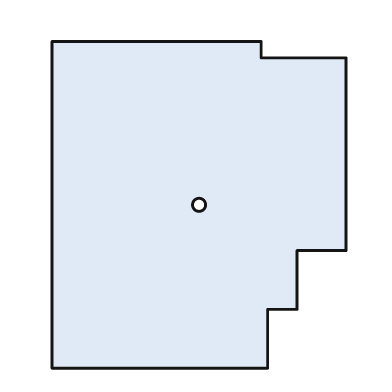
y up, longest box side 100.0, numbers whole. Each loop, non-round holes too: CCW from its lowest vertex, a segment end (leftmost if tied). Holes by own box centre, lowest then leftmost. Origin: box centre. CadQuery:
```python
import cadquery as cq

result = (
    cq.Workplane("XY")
    .moveTo(-45.0, -50.0)
    .lineTo(21.0, -50.0)
    .lineTo(21.0, -32.0)
    .lineTo(30.0, -32.0)
    .lineTo(30.0, -14.0)
    .lineTo(45.0, -14.0)
    .lineTo(45.0, 45.0)
    .lineTo(19.0, 45.0)
    .lineTo(19.0, 50.0)
    .lineTo(-45.0, 50.0)
    .close()
    .moveTo(0.0, 0.0)
    .circle(2.0)
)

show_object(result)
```